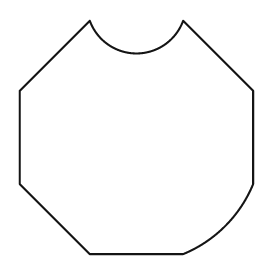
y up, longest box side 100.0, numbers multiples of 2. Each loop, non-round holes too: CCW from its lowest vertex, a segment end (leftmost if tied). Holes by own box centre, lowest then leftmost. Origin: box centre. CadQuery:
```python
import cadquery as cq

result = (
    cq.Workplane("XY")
    .moveTo(-20.0, -50.0)
    .lineTo(20.0, -50.0)
    .threePointArc((38.0, -38.0), (50.0, -20.0))
    .lineTo(50.0, 20.0)
    .lineTo(20.0, 50.0)
    .threePointArc((0.0, 36.0), (-20.0, 50.0))
    .lineTo(-50.0, 20.0)
    .lineTo(-50.0, -20.0)
    .close()
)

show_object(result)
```